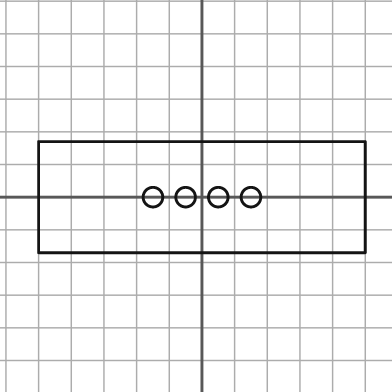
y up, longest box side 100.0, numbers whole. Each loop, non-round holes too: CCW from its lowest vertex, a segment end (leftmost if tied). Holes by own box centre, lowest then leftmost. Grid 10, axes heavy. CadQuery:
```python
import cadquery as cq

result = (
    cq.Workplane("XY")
    .moveTo(-50.0, -17.0)
    .lineTo(50.0, -17.0)
    .lineTo(50.0, 17.0)
    .lineTo(-50.0, 17.0)
    .close()
    .moveTo(-15.0, 0.0)
    .circle(3.0)
    .moveTo(-5.0, 0.0)
    .circle(3.0)
    .moveTo(5.0, 0.0)
    .circle(3.0)
    .moveTo(15.0, 0.0)
    .circle(3.0)
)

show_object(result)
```